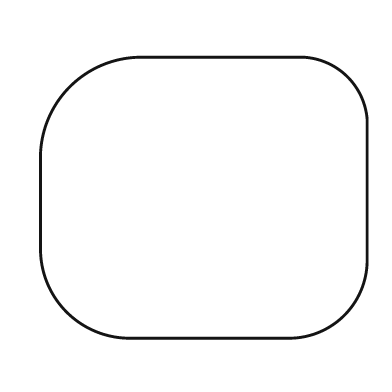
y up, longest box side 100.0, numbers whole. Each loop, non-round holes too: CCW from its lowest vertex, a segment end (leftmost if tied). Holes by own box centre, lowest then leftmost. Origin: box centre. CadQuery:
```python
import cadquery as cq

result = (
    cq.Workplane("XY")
    .moveTo(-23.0, -43.0)
    .lineTo(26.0, -43.0)
    .threePointArc((43.0, -36.0), (50.0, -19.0))
    .lineTo(50.0, 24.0)
    .threePointArc((44.0, 37.0), (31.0, 43.0))
    .lineTo(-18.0, 43.0)
    .threePointArc((-41.0, 34.0), (-50.0, 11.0))
    .lineTo(-50.0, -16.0)
    .threePointArc((-42.0, -35.0), (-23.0, -43.0))
    .close()
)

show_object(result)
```